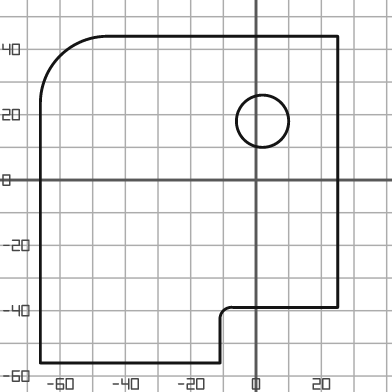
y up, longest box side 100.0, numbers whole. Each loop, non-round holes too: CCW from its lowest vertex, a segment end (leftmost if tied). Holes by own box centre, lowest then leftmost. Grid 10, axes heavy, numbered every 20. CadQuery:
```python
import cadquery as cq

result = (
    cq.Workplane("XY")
    .moveTo(-66.0, -56.0)
    .lineTo(-11.0, -56.0)
    .lineTo(-11.0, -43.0)
    .threePointArc((-10.0, -40.0), (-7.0, -39.0))
    .lineTo(25.0, -39.0)
    .lineTo(25.0, 44.0)
    .lineTo(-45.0, 44.0)
    .threePointArc((-60.0, 38.0), (-66.0, 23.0))
    .close()
    .moveTo(2.0, 18.0)
    .circle(8.0)
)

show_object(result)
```